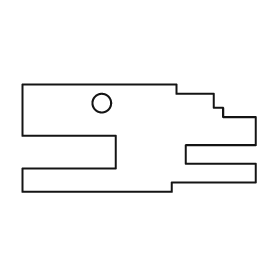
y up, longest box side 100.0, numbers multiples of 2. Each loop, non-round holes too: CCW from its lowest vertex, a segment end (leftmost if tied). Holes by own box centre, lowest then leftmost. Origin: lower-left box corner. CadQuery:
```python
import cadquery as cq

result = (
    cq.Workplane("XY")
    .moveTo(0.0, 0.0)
    .lineTo(64.0, 0.0)
    .lineTo(64.0, 4.0)
    .lineTo(100.0, 4.0)
    .lineTo(100.0, 12.0)
    .lineTo(70.0, 12.0)
    .lineTo(70.0, 20.0)
    .lineTo(100.0, 20.0)
    .lineTo(100.0, 32.0)
    .lineTo(86.0, 32.0)
    .lineTo(86.0, 36.0)
    .lineTo(82.0, 36.0)
    .lineTo(82.0, 42.0)
    .lineTo(66.0, 42.0)
    .lineTo(66.0, 46.0)
    .lineTo(0.0, 46.0)
    .lineTo(0.0, 24.0)
    .lineTo(40.0, 24.0)
    .lineTo(40.0, 10.0)
    .lineTo(0.0, 10.0)
    .close()
    .moveTo(34.0, 38.0)
    .circle(4.0)
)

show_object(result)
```